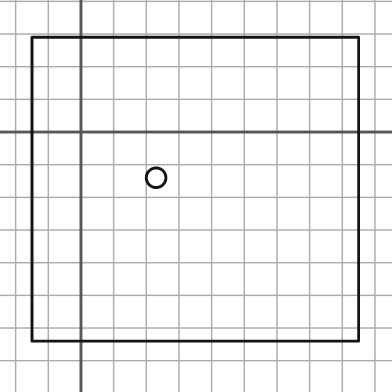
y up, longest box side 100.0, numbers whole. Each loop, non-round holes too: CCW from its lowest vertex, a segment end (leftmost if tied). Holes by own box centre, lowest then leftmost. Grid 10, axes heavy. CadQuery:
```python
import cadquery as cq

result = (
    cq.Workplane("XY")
    .moveTo(-15.0, -64.0)
    .lineTo(85.0, -64.0)
    .lineTo(85.0, 29.0)
    .lineTo(-15.0, 29.0)
    .close()
    .moveTo(23.0, -14.0)
    .circle(3.0)
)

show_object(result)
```